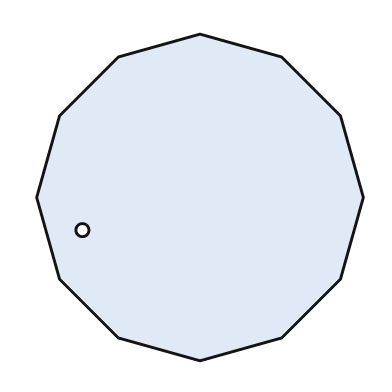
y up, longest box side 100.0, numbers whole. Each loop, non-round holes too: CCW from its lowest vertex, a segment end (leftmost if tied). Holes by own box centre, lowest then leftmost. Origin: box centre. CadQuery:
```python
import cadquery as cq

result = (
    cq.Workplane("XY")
    .moveTo(0.0, -50.0)
    .lineTo(25.0, -43.0)
    .lineTo(43.0, -25.0)
    .lineTo(50.0, 0.0)
    .lineTo(43.0, 25.0)
    .lineTo(25.0, 43.0)
    .lineTo(0.0, 50.0)
    .lineTo(-25.0, 43.0)
    .lineTo(-43.0, 25.0)
    .lineTo(-50.0, 0.0)
    .lineTo(-43.0, -25.0)
    .lineTo(-25.0, -43.0)
    .close()
    .moveTo(-36.0, -10.0)
    .circle(2.0)
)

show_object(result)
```